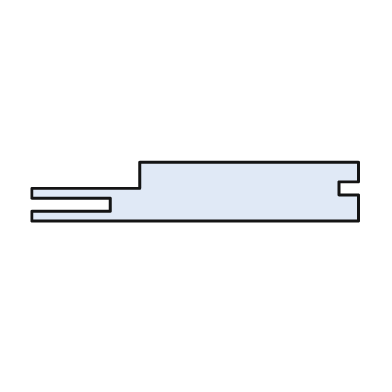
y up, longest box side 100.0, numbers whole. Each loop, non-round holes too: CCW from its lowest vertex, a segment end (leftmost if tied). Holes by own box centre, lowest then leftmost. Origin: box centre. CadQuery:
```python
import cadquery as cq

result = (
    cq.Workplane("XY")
    .moveTo(-50.0, -9.0)
    .lineTo(50.0, -9.0)
    .lineTo(50.0, -1.0)
    .lineTo(44.0, -1.0)
    .lineTo(44.0, 3.0)
    .lineTo(50.0, 3.0)
    .lineTo(50.0, 9.0)
    .lineTo(-17.0, 9.0)
    .lineTo(-17.0, 1.0)
    .lineTo(-50.0, 1.0)
    .lineTo(-50.0, -2.0)
    .lineTo(-26.0, -2.0)
    .lineTo(-26.0, -6.0)
    .lineTo(-50.0, -6.0)
    .close()
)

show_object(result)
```